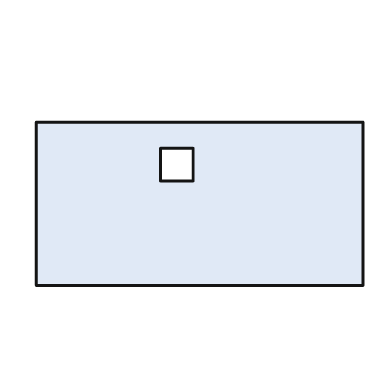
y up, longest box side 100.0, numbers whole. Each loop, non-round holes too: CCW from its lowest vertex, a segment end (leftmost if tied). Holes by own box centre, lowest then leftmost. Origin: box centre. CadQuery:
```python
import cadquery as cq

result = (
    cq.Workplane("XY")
    .moveTo(-50.0, -25.0)
    .lineTo(50.0, -25.0)
    .lineTo(50.0, 25.0)
    .lineTo(-50.0, 25.0)
    .close()
    .moveTo(-12.0, 7.0)
    .lineTo(-2.0, 7.0)
    .lineTo(-2.0, 17.0)
    .lineTo(-12.0, 17.0)
    .close()
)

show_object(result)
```